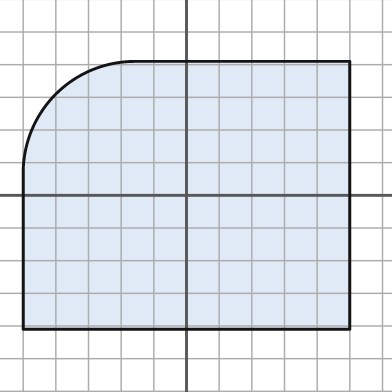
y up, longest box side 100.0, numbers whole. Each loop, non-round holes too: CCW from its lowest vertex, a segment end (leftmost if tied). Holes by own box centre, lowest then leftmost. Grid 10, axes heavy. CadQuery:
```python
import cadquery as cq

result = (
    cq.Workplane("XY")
    .moveTo(-50.0, -41.0)
    .lineTo(50.0, -41.0)
    .lineTo(50.0, 41.0)
    .lineTo(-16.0, 41.0)
    .threePointArc((-40.0, 31.0), (-50.0, 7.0))
    .close()
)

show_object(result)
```